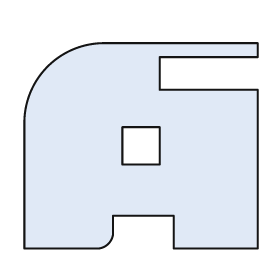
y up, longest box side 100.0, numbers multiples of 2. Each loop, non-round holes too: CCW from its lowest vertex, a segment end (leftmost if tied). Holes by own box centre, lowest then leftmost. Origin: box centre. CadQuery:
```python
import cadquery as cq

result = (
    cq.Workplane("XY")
    .moveTo(-50.0, -44.0)
    .lineTo(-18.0, -44.0)
    .threePointArc((-14.0, -42.0), (-12.0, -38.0))
    .lineTo(-12.0, -30.0)
    .lineTo(14.0, -30.0)
    .lineTo(14.0, -44.0)
    .lineTo(50.0, -44.0)
    .lineTo(50.0, 24.0)
    .lineTo(8.0, 24.0)
    .lineTo(8.0, 38.0)
    .lineTo(50.0, 38.0)
    .lineTo(50.0, 44.0)
    .lineTo(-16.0, 44.0)
    .threePointArc((-40.0, 34.0), (-50.0, 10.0))
    .close()
    .moveTo(-8.0, -8.0)
    .lineTo(8.0, -8.0)
    .lineTo(8.0, 8.0)
    .lineTo(-8.0, 8.0)
    .close()
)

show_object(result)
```